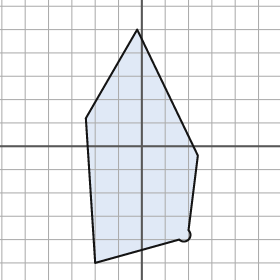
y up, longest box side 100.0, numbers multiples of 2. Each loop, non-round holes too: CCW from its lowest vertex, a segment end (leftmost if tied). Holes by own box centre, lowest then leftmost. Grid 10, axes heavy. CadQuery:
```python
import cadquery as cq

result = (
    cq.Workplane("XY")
    .moveTo(-20.0, -50.0)
    .lineTo(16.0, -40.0)
    .threePointArc((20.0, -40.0), (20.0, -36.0))
    .lineTo(24.0, -4.0)
    .lineTo(-2.0, 50.0)
    .lineTo(-24.0, 12.0)
    .close()
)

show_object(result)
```